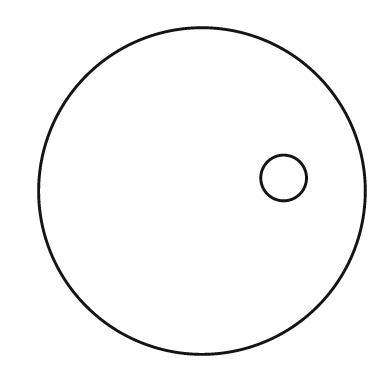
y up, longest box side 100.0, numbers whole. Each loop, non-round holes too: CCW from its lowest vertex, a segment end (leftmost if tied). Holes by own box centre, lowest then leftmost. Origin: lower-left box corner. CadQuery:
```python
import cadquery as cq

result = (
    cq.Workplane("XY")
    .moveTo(50.0, 50.0)
    .circle(50.0)
    .moveTo(75.0, 54.0)
    .circle(7.0)
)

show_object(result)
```